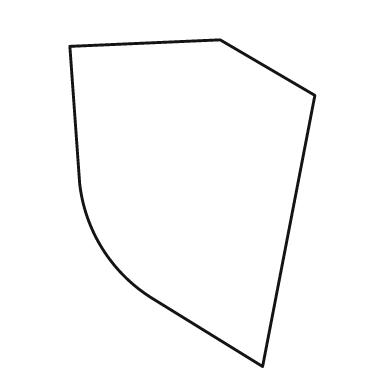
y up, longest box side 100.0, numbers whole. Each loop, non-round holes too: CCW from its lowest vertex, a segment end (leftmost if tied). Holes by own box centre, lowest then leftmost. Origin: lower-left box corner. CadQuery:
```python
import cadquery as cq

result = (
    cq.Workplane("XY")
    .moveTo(59.0, 0.0)
    .lineTo(75.0, 83.0)
    .lineTo(46.0, 100.0)
    .lineTo(0.0, 98.0)
    .lineTo(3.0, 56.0)
    .threePointArc((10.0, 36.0), (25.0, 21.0))
    .close()
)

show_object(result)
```